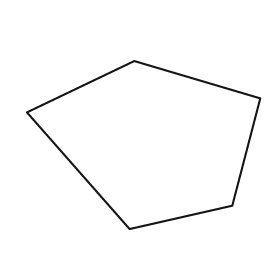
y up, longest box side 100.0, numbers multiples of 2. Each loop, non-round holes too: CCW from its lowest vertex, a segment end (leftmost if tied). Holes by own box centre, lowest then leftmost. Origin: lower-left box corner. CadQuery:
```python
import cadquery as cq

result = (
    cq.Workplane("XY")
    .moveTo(44.0, 0.0)
    .lineTo(88.0, 10.0)
    .lineTo(100.0, 56.0)
    .lineTo(46.0, 72.0)
    .lineTo(0.0, 50.0)
    .close()
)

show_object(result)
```